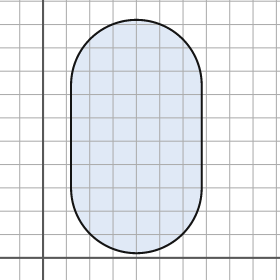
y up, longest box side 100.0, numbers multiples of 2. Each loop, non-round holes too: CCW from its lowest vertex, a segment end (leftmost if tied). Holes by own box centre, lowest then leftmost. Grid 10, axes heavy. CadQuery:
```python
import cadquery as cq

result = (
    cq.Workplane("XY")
    .moveTo(12.0, 30.0)
    .threePointArc((40.0, 2.0), (68.0, 30.0))
    .lineTo(68.0, 74.0)
    .threePointArc((40.0, 102.0), (12.0, 74.0))
    .close()
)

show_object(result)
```